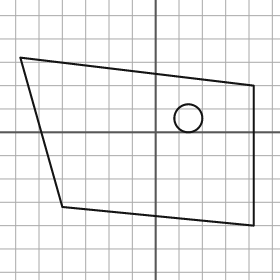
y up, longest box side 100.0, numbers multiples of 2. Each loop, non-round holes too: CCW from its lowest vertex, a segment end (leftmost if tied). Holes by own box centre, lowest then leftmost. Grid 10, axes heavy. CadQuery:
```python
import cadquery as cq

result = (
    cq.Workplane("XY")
    .moveTo(42.0, -40.0)
    .lineTo(42.0, 20.0)
    .lineTo(-58.0, 32.0)
    .lineTo(-40.0, -32.0)
    .close()
    .moveTo(14.0, 6.0)
    .circle(6.0)
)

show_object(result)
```